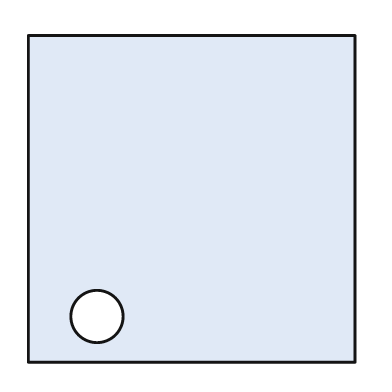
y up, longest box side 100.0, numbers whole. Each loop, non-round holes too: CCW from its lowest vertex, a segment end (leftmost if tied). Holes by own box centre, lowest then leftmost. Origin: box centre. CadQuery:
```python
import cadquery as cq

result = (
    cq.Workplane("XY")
    .moveTo(-50.0, -50.0)
    .lineTo(50.0, -50.0)
    .lineTo(50.0, 50.0)
    .lineTo(-50.0, 50.0)
    .close()
    .moveTo(-29.0, -36.0)
    .circle(8.0)
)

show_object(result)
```